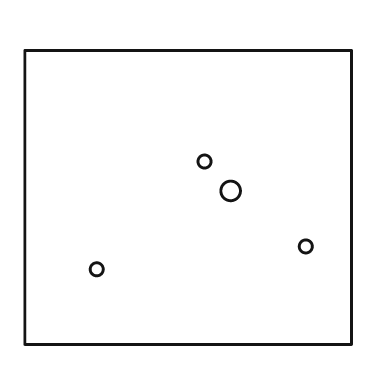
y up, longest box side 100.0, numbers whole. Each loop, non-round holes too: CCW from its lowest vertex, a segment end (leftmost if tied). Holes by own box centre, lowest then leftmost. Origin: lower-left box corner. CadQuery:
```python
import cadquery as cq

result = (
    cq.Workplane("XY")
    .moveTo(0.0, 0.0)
    .lineTo(100.0, 0.0)
    .lineTo(100.0, 90.0)
    .lineTo(0.0, 90.0)
    .close()
    .moveTo(22.0, 23.0)
    .circle(2.0)
    .moveTo(86.0, 30.0)
    .circle(2.0)
    .moveTo(63.0, 47.0)
    .circle(3.0)
    .moveTo(55.0, 56.0)
    .circle(2.0)
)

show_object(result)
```